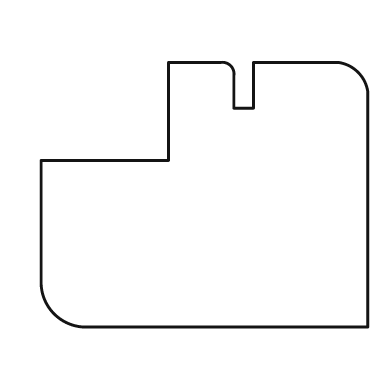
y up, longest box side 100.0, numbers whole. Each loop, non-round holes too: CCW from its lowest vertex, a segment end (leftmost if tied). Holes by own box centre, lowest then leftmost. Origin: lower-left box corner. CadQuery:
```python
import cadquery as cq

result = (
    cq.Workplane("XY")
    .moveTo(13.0, 0.0)
    .lineTo(100.0, 0.0)
    .lineTo(100.0, 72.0)
    .threePointArc((97.0, 78.0), (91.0, 81.0))
    .lineTo(65.0, 81.0)
    .lineTo(65.0, 67.0)
    .lineTo(59.0, 67.0)
    .lineTo(59.0, 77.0)
    .threePointArc((58.0, 80.0), (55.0, 81.0))
    .lineTo(39.0, 81.0)
    .lineTo(39.0, 51.0)
    .lineTo(0.0, 51.0)
    .lineTo(0.0, 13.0)
    .threePointArc((4.0, 4.0), (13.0, 0.0))
    .close()
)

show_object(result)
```